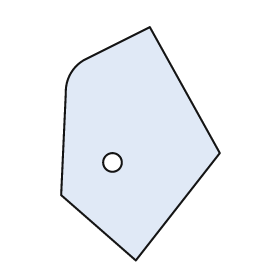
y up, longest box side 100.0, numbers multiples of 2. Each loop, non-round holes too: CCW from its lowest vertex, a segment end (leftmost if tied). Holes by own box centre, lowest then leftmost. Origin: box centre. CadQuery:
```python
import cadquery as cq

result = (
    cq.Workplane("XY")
    .moveTo(-2.0, -50.0)
    .lineTo(34.0, -4.0)
    .lineTo(4.0, 50.0)
    .lineTo(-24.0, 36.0)
    .threePointArc((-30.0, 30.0), (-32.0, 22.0))
    .lineTo(-34.0, -22.0)
    .close()
    .moveTo(-12.0, -8.0)
    .circle(4.0)
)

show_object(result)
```